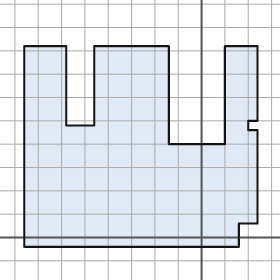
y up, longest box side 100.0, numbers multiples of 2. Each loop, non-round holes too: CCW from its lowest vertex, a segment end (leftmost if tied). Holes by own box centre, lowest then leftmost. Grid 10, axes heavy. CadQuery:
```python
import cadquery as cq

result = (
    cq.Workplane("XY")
    .moveTo(-76.0, -4.0)
    .lineTo(16.0, -4.0)
    .lineTo(16.0, 6.0)
    .lineTo(24.0, 6.0)
    .lineTo(24.0, 46.0)
    .lineTo(20.0, 46.0)
    .lineTo(20.0, 50.0)
    .lineTo(24.0, 50.0)
    .lineTo(24.0, 82.0)
    .lineTo(10.0, 82.0)
    .lineTo(10.0, 40.0)
    .lineTo(-14.0, 40.0)
    .lineTo(-14.0, 82.0)
    .lineTo(-46.0, 82.0)
    .lineTo(-46.0, 48.0)
    .lineTo(-58.0, 48.0)
    .lineTo(-58.0, 82.0)
    .lineTo(-76.0, 82.0)
    .close()
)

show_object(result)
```